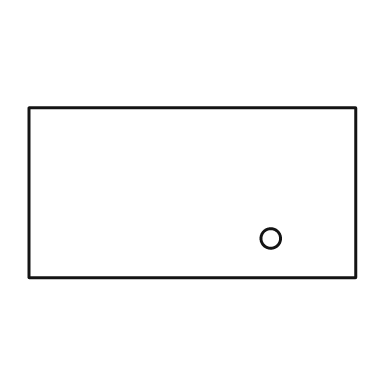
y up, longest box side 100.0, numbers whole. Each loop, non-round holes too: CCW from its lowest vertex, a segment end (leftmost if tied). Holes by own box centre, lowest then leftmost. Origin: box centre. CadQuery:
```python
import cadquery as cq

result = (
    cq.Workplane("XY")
    .moveTo(-50.0, -26.0)
    .lineTo(50.0, -26.0)
    .lineTo(50.0, 26.0)
    .lineTo(-50.0, 26.0)
    .close()
    .moveTo(24.0, -14.0)
    .circle(3.0)
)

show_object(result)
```